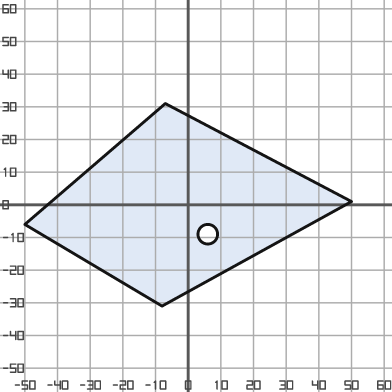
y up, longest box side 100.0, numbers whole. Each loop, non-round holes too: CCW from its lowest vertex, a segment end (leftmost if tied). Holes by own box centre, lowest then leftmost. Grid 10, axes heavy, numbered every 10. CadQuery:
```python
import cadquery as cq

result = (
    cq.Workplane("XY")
    .moveTo(-8.0, -31.0)
    .lineTo(50.0, 1.0)
    .lineTo(-7.0, 31.0)
    .lineTo(-50.0, -6.0)
    .close()
    .moveTo(6.0, -9.0)
    .circle(3.0)
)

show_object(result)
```